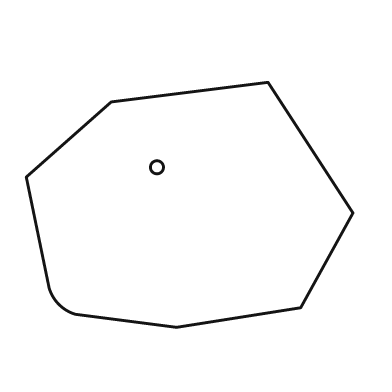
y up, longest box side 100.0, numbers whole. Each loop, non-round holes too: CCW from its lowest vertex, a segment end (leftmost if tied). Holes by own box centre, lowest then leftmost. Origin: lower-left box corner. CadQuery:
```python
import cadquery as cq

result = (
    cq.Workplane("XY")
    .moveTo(46.0, 0.0)
    .lineTo(84.0, 6.0)
    .lineTo(100.0, 35.0)
    .lineTo(74.0, 75.0)
    .lineTo(26.0, 69.0)
    .lineTo(0.0, 46.0)
    .lineTo(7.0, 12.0)
    .threePointArc((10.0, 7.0), (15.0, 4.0))
    .close()
    .moveTo(40.0, 49.0)
    .circle(2.0)
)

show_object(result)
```